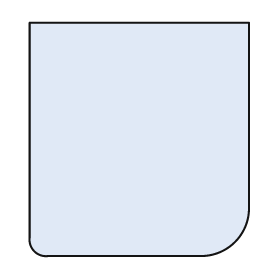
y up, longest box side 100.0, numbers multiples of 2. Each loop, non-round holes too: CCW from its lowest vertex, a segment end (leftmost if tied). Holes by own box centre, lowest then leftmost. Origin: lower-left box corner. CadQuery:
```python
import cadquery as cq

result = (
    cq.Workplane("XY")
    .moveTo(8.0, 0.0)
    .lineTo(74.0, 0.0)
    .threePointArc((88.0, 6.0), (94.0, 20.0))
    .lineTo(94.0, 100.0)
    .lineTo(0.0, 100.0)
    .lineTo(0.0, 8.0)
    .threePointArc((2.0, 2.0), (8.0, 0.0))
    .close()
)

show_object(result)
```